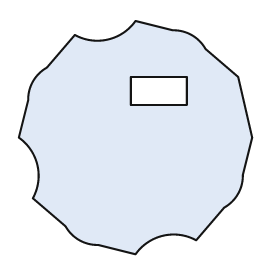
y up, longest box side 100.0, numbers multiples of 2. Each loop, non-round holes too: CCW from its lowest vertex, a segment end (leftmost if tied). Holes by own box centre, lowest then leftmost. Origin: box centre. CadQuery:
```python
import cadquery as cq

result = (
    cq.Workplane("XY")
    .moveTo(0.0, -50.0)
    .threePointArc((12.0, -42.0), (26.0, -44.0))
    .lineTo(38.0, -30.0)
    .threePointArc((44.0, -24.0), (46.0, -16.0))
    .lineTo(50.0, 0.0)
    .lineTo(44.0, 26.0)
    .lineTo(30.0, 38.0)
    .threePointArc((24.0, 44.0), (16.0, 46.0))
    .lineTo(0.0, 50.0)
    .threePointArc((-12.0, 42.0), (-26.0, 44.0))
    .lineTo(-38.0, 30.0)
    .threePointArc((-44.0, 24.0), (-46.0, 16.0))
    .lineTo(-50.0, 0.0)
    .threePointArc((-42.0, -12.0), (-44.0, -26.0))
    .lineTo(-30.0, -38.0)
    .threePointArc((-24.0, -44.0), (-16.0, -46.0))
    .close()
    .moveTo(-2.0, 14.0)
    .lineTo(22.0, 14.0)
    .lineTo(22.0, 26.0)
    .lineTo(-2.0, 26.0)
    .close()
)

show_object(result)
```